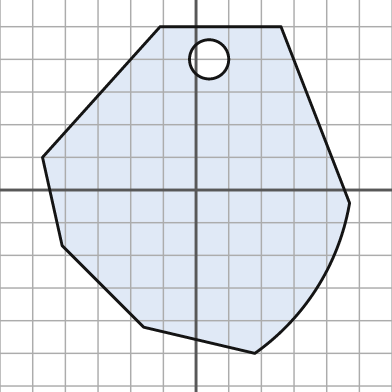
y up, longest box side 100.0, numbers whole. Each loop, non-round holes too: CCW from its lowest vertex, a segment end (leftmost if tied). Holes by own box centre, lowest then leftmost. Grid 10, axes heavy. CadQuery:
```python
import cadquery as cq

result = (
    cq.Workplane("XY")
    .moveTo(18.0, -50.0)
    .threePointArc((37.0, -30.0), (47.0, -4.0))
    .lineTo(26.0, 50.0)
    .lineTo(-11.0, 50.0)
    .lineTo(-47.0, 10.0)
    .lineTo(-41.0, -17.0)
    .lineTo(-16.0, -42.0)
    .close()
    .moveTo(4.0, 40.0)
    .circle(6.0)
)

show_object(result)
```